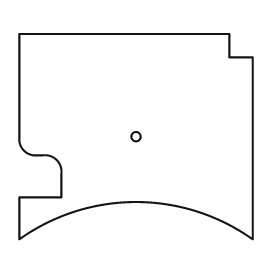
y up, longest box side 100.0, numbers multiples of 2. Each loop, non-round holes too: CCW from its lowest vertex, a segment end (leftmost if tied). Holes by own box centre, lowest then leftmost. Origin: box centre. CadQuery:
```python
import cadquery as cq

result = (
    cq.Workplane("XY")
    .moveTo(-50.0, -44.0)
    .threePointArc((0.0, -28.0), (50.0, -44.0))
    .lineTo(50.0, 34.0)
    .lineTo(40.0, 34.0)
    .lineTo(40.0, 44.0)
    .lineTo(-50.0, 44.0)
    .lineTo(-50.0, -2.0)
    .threePointArc((-48.0, -6.0), (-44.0, -8.0))
    .lineTo(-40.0, -8.0)
    .threePointArc((-34.0, -10.0), (-32.0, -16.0))
    .lineTo(-32.0, -26.0)
    .lineTo(-50.0, -26.0)
    .close()
    .moveTo(0.0, 0.0)
    .circle(2.0)
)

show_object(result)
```